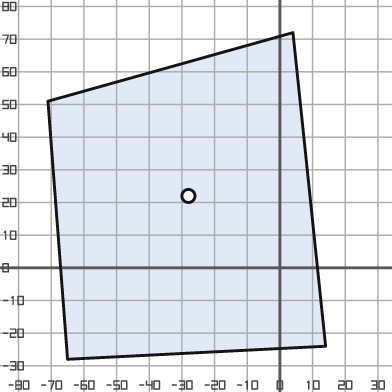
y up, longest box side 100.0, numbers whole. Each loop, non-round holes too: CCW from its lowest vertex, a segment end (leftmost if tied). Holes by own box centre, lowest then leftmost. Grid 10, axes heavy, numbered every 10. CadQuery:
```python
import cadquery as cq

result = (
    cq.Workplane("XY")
    .moveTo(-65.0, -28.0)
    .lineTo(14.0, -24.0)
    .lineTo(4.0, 72.0)
    .lineTo(-71.0, 51.0)
    .close()
    .moveTo(-28.0, 22.0)
    .circle(2.0)
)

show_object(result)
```